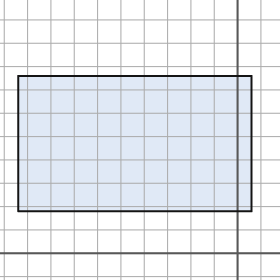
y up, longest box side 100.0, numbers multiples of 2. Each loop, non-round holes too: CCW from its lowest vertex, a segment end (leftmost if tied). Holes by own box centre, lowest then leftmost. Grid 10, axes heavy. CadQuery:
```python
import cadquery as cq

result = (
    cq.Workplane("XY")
    .moveTo(-94.0, 18.0)
    .lineTo(6.0, 18.0)
    .lineTo(6.0, 76.0)
    .lineTo(-94.0, 76.0)
    .close()
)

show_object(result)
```